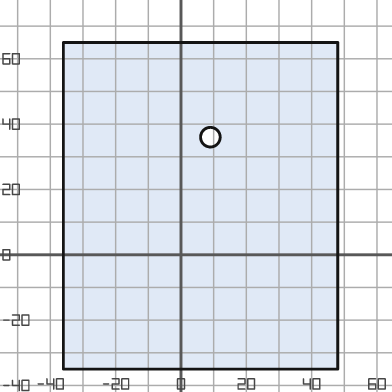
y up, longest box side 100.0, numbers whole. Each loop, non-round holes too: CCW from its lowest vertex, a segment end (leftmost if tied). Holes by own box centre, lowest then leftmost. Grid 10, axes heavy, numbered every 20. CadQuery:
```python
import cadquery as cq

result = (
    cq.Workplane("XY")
    .moveTo(-36.0, -35.0)
    .lineTo(48.0, -35.0)
    .lineTo(48.0, 65.0)
    .lineTo(-36.0, 65.0)
    .close()
    .moveTo(9.0, 36.0)
    .circle(3.0)
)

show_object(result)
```